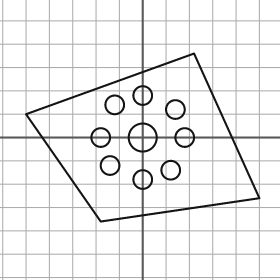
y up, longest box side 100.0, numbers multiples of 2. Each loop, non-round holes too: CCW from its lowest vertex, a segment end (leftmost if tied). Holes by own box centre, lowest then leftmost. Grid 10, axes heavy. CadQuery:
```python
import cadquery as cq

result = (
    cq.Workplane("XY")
    .moveTo(-18.0, -36.0)
    .lineTo(50.0, -26.0)
    .lineTo(22.0, 36.0)
    .lineTo(-50.0, 10.0)
    .close()
    .moveTo(0.0, -18.0)
    .circle(4.0)
    .moveTo(12.0, -14.0)
    .circle(4.0)
    .moveTo(-14.0, -12.0)
    .circle(4.0)
    .moveTo(-18.0, 0.0)
    .circle(4.0)
    .moveTo(0.0, 0.0)
    .circle(6.0)
    .moveTo(18.0, 0.0)
    .circle(4.0)
    .moveTo(14.0, 12.0)
    .circle(4.0)
    .moveTo(-12.0, 14.0)
    .circle(4.0)
    .moveTo(0.0, 18.0)
    .circle(4.0)
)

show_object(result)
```